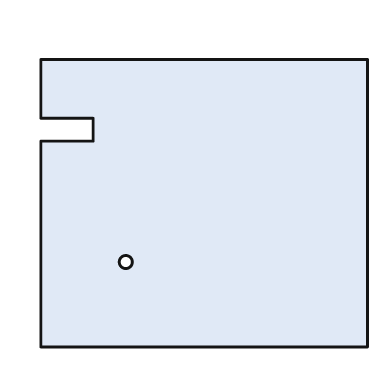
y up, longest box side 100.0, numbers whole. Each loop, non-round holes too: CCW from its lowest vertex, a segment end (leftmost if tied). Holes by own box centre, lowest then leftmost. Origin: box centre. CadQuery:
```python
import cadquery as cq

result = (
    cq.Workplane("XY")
    .moveTo(-50.0, -44.0)
    .lineTo(50.0, -44.0)
    .lineTo(50.0, 44.0)
    .lineTo(-50.0, 44.0)
    .lineTo(-50.0, 26.0)
    .lineTo(-34.0, 26.0)
    .lineTo(-34.0, 19.0)
    .lineTo(-50.0, 19.0)
    .close()
    .moveTo(-24.0, -18.0)
    .circle(2.0)
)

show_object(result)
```